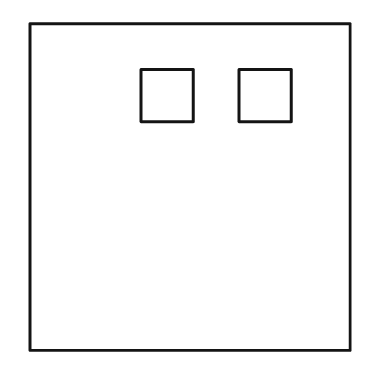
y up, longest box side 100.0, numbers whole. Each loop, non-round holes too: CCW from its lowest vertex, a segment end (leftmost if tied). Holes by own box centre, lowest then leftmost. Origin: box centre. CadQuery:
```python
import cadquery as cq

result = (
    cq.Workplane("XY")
    .moveTo(-49.0, -50.0)
    .lineTo(49.0, -50.0)
    .lineTo(49.0, 50.0)
    .lineTo(-49.0, 50.0)
    .close()
    .moveTo(-15.0, 20.0)
    .lineTo(1.0, 20.0)
    .lineTo(1.0, 36.0)
    .lineTo(-15.0, 36.0)
    .close()
    .moveTo(15.0, 20.0)
    .lineTo(31.0, 20.0)
    .lineTo(31.0, 36.0)
    .lineTo(15.0, 36.0)
    .close()
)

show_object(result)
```